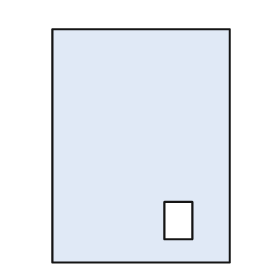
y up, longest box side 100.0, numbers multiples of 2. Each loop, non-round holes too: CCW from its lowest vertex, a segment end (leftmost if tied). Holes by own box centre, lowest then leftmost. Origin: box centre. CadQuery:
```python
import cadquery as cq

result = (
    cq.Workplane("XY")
    .moveTo(-38.0, -50.0)
    .lineTo(38.0, -50.0)
    .lineTo(38.0, 50.0)
    .lineTo(-38.0, 50.0)
    .close()
    .moveTo(10.0, -40.0)
    .lineTo(22.0, -40.0)
    .lineTo(22.0, -24.0)
    .lineTo(10.0, -24.0)
    .close()
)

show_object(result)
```